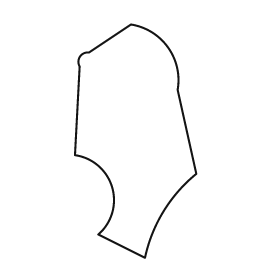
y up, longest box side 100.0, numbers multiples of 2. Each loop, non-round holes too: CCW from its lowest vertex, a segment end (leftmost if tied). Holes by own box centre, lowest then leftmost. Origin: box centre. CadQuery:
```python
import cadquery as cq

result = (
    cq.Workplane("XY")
    .moveTo(4.0, -50.0)
    .threePointArc((12.0, -30.0), (26.0, -14.0))
    .lineTo(18.0, 22.0)
    .threePointArc((14.0, 40.0), (-2.0, 50.0))
    .lineTo(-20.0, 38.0)
    .threePointArc((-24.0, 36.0), (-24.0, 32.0))
    .lineTo(-26.0, -6.0)
    .threePointArc((-10.0, -20.0), (-16.0, -40.0))
    .close()
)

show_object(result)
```